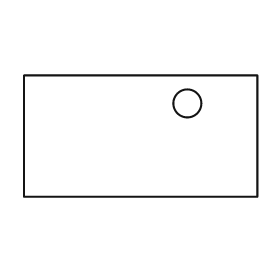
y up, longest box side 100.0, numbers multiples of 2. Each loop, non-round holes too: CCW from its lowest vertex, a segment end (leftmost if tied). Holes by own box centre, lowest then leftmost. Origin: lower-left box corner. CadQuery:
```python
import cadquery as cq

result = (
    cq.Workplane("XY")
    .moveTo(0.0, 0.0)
    .lineTo(100.0, 0.0)
    .lineTo(100.0, 52.0)
    .lineTo(0.0, 52.0)
    .close()
    .moveTo(70.0, 40.0)
    .circle(6.0)
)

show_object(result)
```